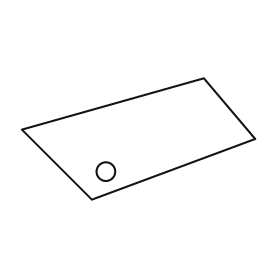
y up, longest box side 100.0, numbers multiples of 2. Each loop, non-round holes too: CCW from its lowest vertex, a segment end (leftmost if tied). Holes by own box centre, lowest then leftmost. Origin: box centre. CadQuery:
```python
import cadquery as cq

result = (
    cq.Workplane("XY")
    .moveTo(-20.0, -26.0)
    .lineTo(50.0, 0.0)
    .lineTo(28.0, 26.0)
    .lineTo(-50.0, 4.0)
    .close()
    .moveTo(-14.0, -14.0)
    .circle(4.0)
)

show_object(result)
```